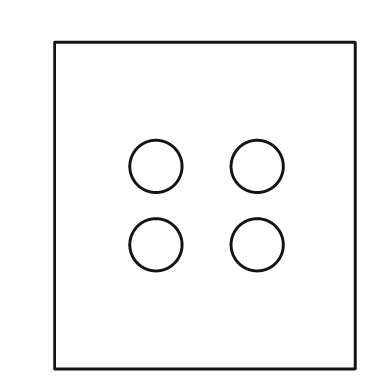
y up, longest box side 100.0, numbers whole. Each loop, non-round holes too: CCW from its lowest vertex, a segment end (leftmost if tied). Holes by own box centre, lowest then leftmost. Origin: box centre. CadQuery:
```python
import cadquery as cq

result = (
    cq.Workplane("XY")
    .moveTo(-46.0, -50.0)
    .lineTo(46.0, -50.0)
    .lineTo(46.0, 50.0)
    .lineTo(-46.0, 50.0)
    .close()
    .moveTo(-15.0, -12.0)
    .circle(8.0)
    .moveTo(16.0, -12.0)
    .circle(8.0)
    .moveTo(-15.0, 12.0)
    .circle(8.0)
    .moveTo(16.0, 12.0)
    .circle(8.0)
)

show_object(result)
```